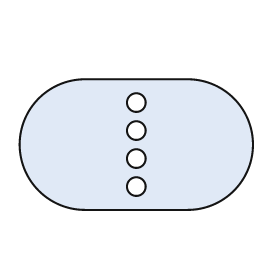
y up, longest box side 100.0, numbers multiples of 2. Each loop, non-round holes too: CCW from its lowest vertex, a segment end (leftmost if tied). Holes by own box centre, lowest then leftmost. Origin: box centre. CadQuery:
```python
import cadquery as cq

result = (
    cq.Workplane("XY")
    .moveTo(-22.0, -28.0)
    .lineTo(22.0, -28.0)
    .threePointArc((50.0, 0.0), (22.0, 28.0))
    .lineTo(-22.0, 28.0)
    .threePointArc((-50.0, 0.0), (-22.0, -28.0))
    .close()
    .moveTo(0.0, -18.0)
    .circle(4.0)
    .moveTo(0.0, -6.0)
    .circle(4.0)
    .moveTo(0.0, 6.0)
    .circle(4.0)
    .moveTo(0.0, 18.0)
    .circle(4.0)
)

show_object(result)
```